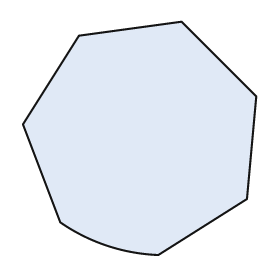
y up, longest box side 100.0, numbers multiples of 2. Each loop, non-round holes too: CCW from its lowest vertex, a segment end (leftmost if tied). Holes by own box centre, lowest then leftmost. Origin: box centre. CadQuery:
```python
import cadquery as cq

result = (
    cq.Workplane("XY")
    .moveTo(8.0, -50.0)
    .lineTo(46.0, -26.0)
    .lineTo(50.0, 18.0)
    .lineTo(18.0, 50.0)
    .lineTo(-26.0, 44.0)
    .lineTo(-50.0, 6.0)
    .lineTo(-34.0, -36.0)
    .threePointArc((-14.0, -46.0), (8.0, -50.0))
    .close()
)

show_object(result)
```